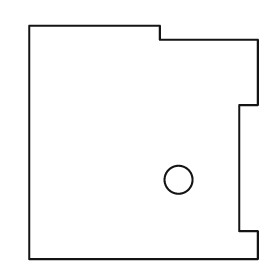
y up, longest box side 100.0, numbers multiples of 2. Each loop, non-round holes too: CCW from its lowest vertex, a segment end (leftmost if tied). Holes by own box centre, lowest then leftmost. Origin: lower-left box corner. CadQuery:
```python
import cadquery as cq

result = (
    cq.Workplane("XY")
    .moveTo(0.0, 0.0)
    .lineTo(98.0, 0.0)
    .lineTo(98.0, 12.0)
    .lineTo(90.0, 12.0)
    .lineTo(90.0, 66.0)
    .lineTo(98.0, 66.0)
    .lineTo(98.0, 94.0)
    .lineTo(56.0, 94.0)
    .lineTo(56.0, 100.0)
    .lineTo(0.0, 100.0)
    .close()
    .moveTo(64.0, 34.0)
    .circle(6.0)
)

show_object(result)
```